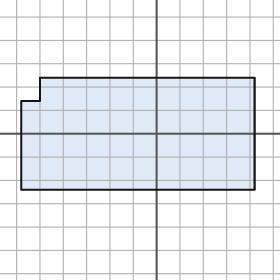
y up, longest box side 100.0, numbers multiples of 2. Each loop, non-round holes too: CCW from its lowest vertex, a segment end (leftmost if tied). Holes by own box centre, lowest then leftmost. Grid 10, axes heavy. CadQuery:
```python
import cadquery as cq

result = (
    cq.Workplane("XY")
    .moveTo(-58.0, -24.0)
    .lineTo(42.0, -24.0)
    .lineTo(42.0, 24.0)
    .lineTo(-50.0, 24.0)
    .lineTo(-50.0, 14.0)
    .lineTo(-58.0, 14.0)
    .close()
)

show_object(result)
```